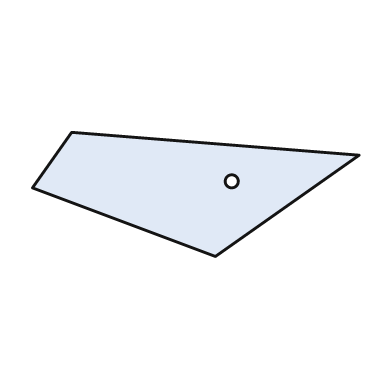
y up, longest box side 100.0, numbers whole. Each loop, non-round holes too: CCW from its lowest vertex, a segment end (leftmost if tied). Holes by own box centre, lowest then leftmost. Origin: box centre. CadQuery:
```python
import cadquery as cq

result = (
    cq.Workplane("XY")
    .moveTo(6.0, -19.0)
    .lineTo(50.0, 12.0)
    .lineTo(-38.0, 19.0)
    .lineTo(-50.0, 2.0)
    .close()
    .moveTo(11.0, 4.0)
    .circle(2.0)
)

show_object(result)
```